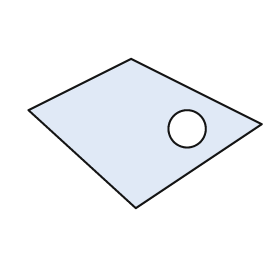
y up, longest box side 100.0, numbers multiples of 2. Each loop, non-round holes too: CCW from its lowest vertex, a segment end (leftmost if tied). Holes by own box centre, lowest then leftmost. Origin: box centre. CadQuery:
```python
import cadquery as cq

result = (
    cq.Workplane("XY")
    .moveTo(-4.0, -32.0)
    .lineTo(50.0, 4.0)
    .lineTo(-6.0, 32.0)
    .lineTo(-50.0, 10.0)
    .close()
    .moveTo(18.0, 2.0)
    .circle(8.0)
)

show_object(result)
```